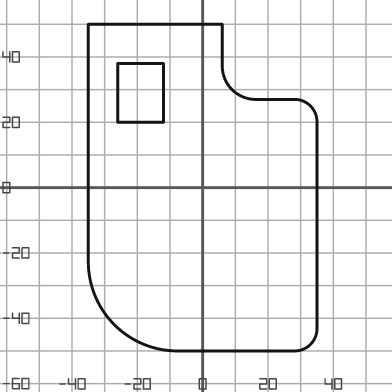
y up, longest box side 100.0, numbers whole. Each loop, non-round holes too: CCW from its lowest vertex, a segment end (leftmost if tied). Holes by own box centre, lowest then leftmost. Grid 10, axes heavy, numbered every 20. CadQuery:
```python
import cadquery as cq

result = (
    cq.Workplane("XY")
    .moveTo(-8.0, -50.0)
    .lineTo(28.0, -50.0)
    .threePointArc((33.0, -48.0), (35.0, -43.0))
    .lineTo(35.0, 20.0)
    .threePointArc((33.0, 25.0), (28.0, 27.0))
    .lineTo(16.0, 27.0)
    .threePointArc((9.0, 30.0), (6.0, 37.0))
    .lineTo(6.0, 50.0)
    .lineTo(-35.0, 50.0)
    .lineTo(-35.0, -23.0)
    .threePointArc((-27.0, -42.0), (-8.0, -50.0))
    .close()
    .moveTo(-26.0, 20.0)
    .lineTo(-12.0, 20.0)
    .lineTo(-12.0, 38.0)
    .lineTo(-26.0, 38.0)
    .close()
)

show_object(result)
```